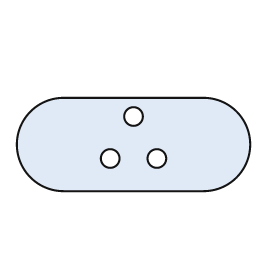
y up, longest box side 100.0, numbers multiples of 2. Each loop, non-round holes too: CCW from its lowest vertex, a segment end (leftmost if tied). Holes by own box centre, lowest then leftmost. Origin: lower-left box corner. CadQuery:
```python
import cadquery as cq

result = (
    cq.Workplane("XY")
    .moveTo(20.0, 0.0)
    .lineTo(80.0, 0.0)
    .threePointArc((100.0, 20.0), (80.0, 40.0))
    .lineTo(20.0, 40.0)
    .threePointArc((0.0, 20.0), (20.0, 0.0))
    .close()
    .moveTo(40.0, 14.0)
    .circle(4.0)
    .moveTo(60.0, 14.0)
    .circle(4.0)
    .moveTo(50.0, 32.0)
    .circle(4.0)
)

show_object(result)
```